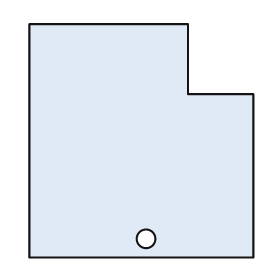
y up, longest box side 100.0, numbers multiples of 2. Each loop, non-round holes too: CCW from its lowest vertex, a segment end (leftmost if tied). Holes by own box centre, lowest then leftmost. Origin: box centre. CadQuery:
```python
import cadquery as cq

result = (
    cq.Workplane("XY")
    .moveTo(-48.0, -50.0)
    .lineTo(48.0, -50.0)
    .lineTo(48.0, 20.0)
    .lineTo(20.0, 20.0)
    .lineTo(20.0, 50.0)
    .lineTo(-48.0, 50.0)
    .close()
    .moveTo(2.0, -42.0)
    .circle(4.0)
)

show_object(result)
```